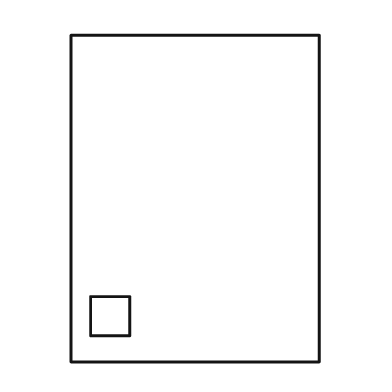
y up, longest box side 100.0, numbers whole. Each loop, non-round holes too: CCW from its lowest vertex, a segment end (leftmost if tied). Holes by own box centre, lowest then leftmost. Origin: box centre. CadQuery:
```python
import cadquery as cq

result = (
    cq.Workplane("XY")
    .moveTo(-38.0, -50.0)
    .lineTo(38.0, -50.0)
    .lineTo(38.0, 50.0)
    .lineTo(-38.0, 50.0)
    .close()
    .moveTo(-32.0, -42.0)
    .lineTo(-20.0, -42.0)
    .lineTo(-20.0, -30.0)
    .lineTo(-32.0, -30.0)
    .close()
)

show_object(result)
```